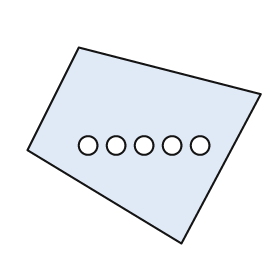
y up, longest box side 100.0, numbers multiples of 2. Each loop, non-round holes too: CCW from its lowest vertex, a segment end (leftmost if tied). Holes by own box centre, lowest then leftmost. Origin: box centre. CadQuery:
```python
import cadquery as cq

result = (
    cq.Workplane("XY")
    .moveTo(16.0, -42.0)
    .lineTo(50.0, 22.0)
    .lineTo(-28.0, 42.0)
    .lineTo(-50.0, -2.0)
    .close()
    .moveTo(-24.0, 0.0)
    .circle(4.0)
    .moveTo(-12.0, 0.0)
    .circle(4.0)
    .moveTo(0.0, 0.0)
    .circle(4.0)
    .moveTo(12.0, 0.0)
    .circle(4.0)
    .moveTo(24.0, 0.0)
    .circle(4.0)
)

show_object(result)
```